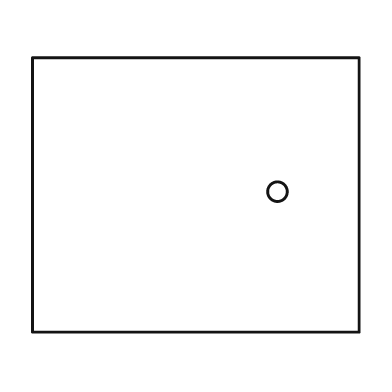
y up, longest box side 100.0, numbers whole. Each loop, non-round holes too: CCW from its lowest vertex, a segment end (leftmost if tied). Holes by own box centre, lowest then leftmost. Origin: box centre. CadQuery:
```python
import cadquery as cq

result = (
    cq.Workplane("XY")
    .moveTo(-50.0, -42.0)
    .lineTo(50.0, -42.0)
    .lineTo(50.0, 42.0)
    .lineTo(-50.0, 42.0)
    .close()
    .moveTo(25.0, 1.0)
    .circle(3.0)
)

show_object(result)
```